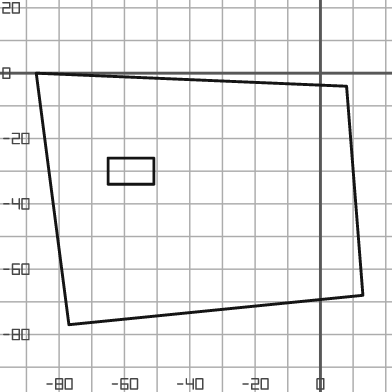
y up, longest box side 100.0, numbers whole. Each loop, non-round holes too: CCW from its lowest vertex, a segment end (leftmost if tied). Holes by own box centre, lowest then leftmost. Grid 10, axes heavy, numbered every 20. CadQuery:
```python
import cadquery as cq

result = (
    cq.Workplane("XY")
    .moveTo(-77.0, -77.0)
    .lineTo(13.0, -68.0)
    .lineTo(8.0, -4.0)
    .lineTo(-87.0, 0.0)
    .close()
    .moveTo(-65.0, -34.0)
    .lineTo(-51.0, -34.0)
    .lineTo(-51.0, -26.0)
    .lineTo(-65.0, -26.0)
    .close()
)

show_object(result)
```